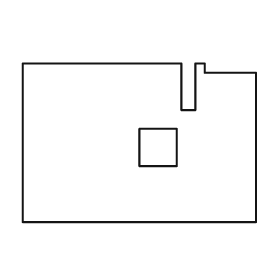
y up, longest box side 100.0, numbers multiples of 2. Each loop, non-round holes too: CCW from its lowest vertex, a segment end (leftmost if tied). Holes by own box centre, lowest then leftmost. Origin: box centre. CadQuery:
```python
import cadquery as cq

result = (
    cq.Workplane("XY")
    .moveTo(-50.0, -34.0)
    .lineTo(50.0, -34.0)
    .lineTo(50.0, 30.0)
    .lineTo(28.0, 30.0)
    .lineTo(28.0, 34.0)
    .lineTo(24.0, 34.0)
    .lineTo(24.0, 14.0)
    .lineTo(18.0, 14.0)
    .lineTo(18.0, 34.0)
    .lineTo(-50.0, 34.0)
    .close()
    .moveTo(0.0, -10.0)
    .lineTo(16.0, -10.0)
    .lineTo(16.0, 6.0)
    .lineTo(0.0, 6.0)
    .close()
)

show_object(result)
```